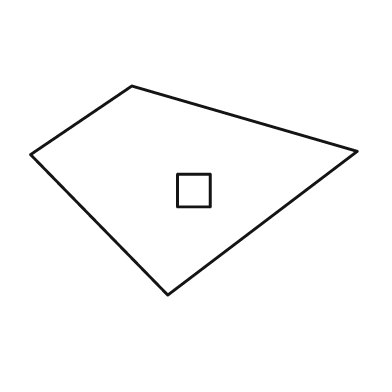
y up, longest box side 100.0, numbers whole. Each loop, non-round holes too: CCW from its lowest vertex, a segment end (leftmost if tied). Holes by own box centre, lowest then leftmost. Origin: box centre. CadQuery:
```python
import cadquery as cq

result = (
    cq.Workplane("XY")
    .moveTo(-8.0, -32.0)
    .lineTo(50.0, 12.0)
    .lineTo(-19.0, 32.0)
    .lineTo(-50.0, 11.0)
    .close()
    .moveTo(-5.0, -5.0)
    .lineTo(5.0, -5.0)
    .lineTo(5.0, 5.0)
    .lineTo(-5.0, 5.0)
    .close()
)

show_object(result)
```